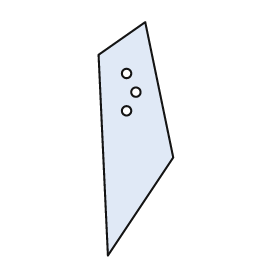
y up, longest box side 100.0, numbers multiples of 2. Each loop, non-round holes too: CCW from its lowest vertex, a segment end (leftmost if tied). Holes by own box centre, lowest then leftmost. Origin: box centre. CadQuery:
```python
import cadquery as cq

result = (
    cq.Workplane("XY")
    .moveTo(-12.0, -50.0)
    .lineTo(16.0, -8.0)
    .lineTo(4.0, 50.0)
    .lineTo(-16.0, 36.0)
    .close()
    .moveTo(-4.0, 12.0)
    .circle(2.0)
    .moveTo(0.0, 20.0)
    .circle(2.0)
    .moveTo(-4.0, 28.0)
    .circle(2.0)
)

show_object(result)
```